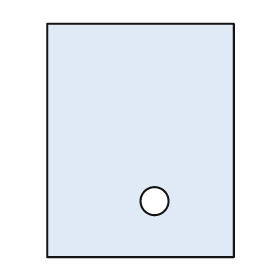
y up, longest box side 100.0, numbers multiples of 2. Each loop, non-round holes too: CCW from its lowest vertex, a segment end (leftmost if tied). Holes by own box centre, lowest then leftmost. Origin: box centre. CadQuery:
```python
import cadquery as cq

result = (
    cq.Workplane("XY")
    .moveTo(-40.0, -50.0)
    .lineTo(40.0, -50.0)
    .lineTo(40.0, 50.0)
    .lineTo(-40.0, 50.0)
    .close()
    .moveTo(6.0, -26.0)
    .circle(6.0)
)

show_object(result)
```